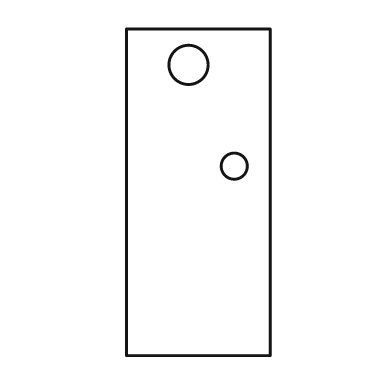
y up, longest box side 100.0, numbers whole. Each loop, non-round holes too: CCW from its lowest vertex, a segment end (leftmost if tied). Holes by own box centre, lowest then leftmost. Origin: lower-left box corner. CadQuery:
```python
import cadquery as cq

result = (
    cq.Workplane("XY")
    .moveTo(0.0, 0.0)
    .lineTo(44.0, 0.0)
    .lineTo(44.0, 100.0)
    .lineTo(0.0, 100.0)
    .close()
    .moveTo(33.0, 58.0)
    .circle(4.0)
    .moveTo(19.0, 89.0)
    .circle(6.0)
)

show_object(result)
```